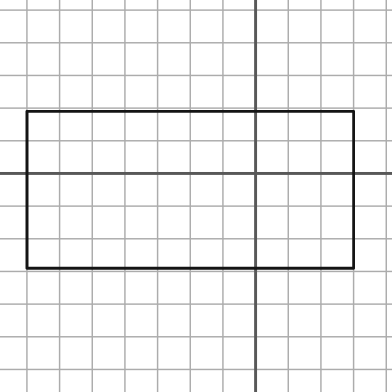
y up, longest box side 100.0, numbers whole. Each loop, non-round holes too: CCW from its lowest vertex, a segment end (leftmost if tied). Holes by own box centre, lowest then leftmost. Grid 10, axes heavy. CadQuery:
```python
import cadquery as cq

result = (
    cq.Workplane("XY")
    .moveTo(-70.0, -29.0)
    .lineTo(30.0, -29.0)
    .lineTo(30.0, 19.0)
    .lineTo(-70.0, 19.0)
    .close()
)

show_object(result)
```